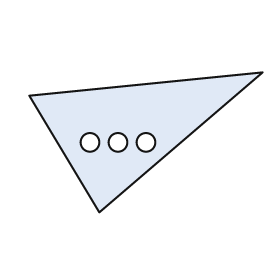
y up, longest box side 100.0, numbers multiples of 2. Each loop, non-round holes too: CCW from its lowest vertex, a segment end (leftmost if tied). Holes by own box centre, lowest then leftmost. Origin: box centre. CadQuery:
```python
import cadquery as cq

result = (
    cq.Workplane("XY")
    .moveTo(-20.0, -30.0)
    .lineTo(50.0, 30.0)
    .lineTo(-50.0, 20.0)
    .close()
    .moveTo(-24.0, 0.0)
    .circle(4.0)
    .moveTo(-12.0, 0.0)
    .circle(4.0)
    .moveTo(0.0, 0.0)
    .circle(4.0)
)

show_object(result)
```